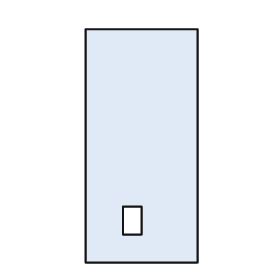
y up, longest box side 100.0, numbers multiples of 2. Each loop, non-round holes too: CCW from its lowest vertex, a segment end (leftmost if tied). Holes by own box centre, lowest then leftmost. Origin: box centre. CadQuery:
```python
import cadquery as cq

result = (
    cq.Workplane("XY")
    .moveTo(-24.0, -50.0)
    .lineTo(24.0, -50.0)
    .lineTo(24.0, 50.0)
    .lineTo(-24.0, 50.0)
    .close()
    .moveTo(-8.0, -38.0)
    .lineTo(0.0, -38.0)
    .lineTo(0.0, -26.0)
    .lineTo(-8.0, -26.0)
    .close()
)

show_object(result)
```